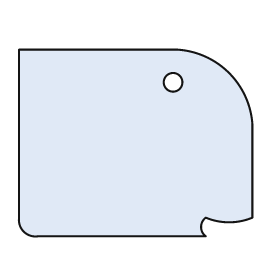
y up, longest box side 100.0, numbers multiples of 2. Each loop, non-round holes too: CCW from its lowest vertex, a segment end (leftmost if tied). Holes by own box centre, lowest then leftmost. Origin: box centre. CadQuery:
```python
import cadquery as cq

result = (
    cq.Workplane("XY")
    .moveTo(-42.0, -40.0)
    .lineTo(30.0, -40.0)
    .threePointArc((28.0, -36.0), (30.0, -32.0))
    .threePointArc((40.0, -34.0), (50.0, -32.0))
    .lineTo(50.0, 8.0)
    .threePointArc((40.0, 30.0), (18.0, 40.0))
    .lineTo(-50.0, 40.0)
    .lineTo(-50.0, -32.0)
    .threePointArc((-48.0, -38.0), (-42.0, -40.0))
    .close()
    .moveTo(16.0, 26.0)
    .circle(4.0)
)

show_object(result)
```